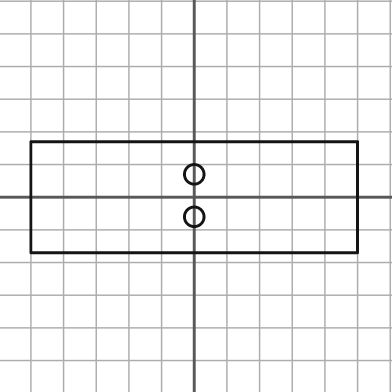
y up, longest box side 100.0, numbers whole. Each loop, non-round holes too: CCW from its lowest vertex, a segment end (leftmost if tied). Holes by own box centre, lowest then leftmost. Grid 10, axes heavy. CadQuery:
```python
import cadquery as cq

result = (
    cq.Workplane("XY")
    .moveTo(-50.0, -17.0)
    .lineTo(50.0, -17.0)
    .lineTo(50.0, 17.0)
    .lineTo(-50.0, 17.0)
    .close()
    .moveTo(0.0, -6.0)
    .circle(3.0)
    .moveTo(0.0, 7.0)
    .circle(3.0)
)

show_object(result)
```